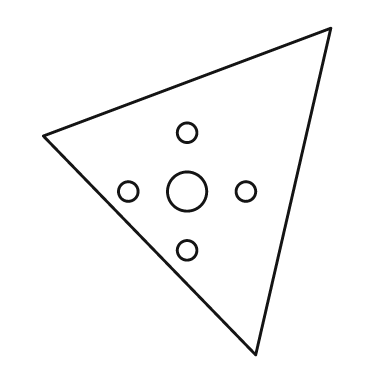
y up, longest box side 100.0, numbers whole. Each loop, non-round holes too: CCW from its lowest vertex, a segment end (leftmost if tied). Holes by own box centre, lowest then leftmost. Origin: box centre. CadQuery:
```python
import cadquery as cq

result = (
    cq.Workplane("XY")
    .moveTo(21.0, -50.0)
    .lineTo(44.0, 50.0)
    .lineTo(-44.0, 17.0)
    .close()
    .moveTo(0.0, -18.0)
    .circle(3.0)
    .moveTo(-18.0, 0.0)
    .circle(3.0)
    .moveTo(0.0, 0.0)
    .circle(6.0)
    .moveTo(18.0, 0.0)
    .circle(3.0)
    .moveTo(0.0, 18.0)
    .circle(3.0)
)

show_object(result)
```